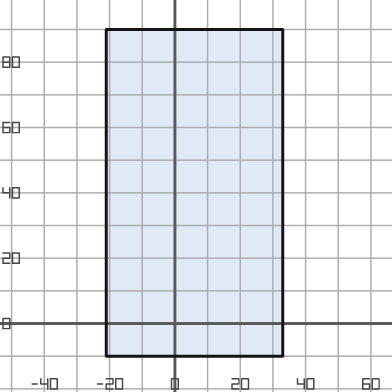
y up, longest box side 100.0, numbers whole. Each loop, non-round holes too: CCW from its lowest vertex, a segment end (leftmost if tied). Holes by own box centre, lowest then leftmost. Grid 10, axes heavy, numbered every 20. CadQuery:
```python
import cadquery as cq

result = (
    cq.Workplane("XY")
    .moveTo(-21.0, -10.0)
    .lineTo(33.0, -10.0)
    .lineTo(33.0, 90.0)
    .lineTo(-21.0, 90.0)
    .close()
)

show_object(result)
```